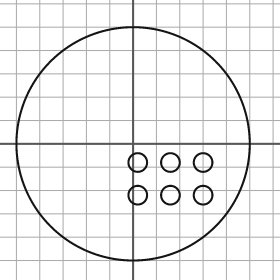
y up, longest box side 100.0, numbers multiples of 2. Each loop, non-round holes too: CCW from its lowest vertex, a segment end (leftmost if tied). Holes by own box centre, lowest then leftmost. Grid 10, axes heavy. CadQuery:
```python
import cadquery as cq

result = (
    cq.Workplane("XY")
    .moveTo(0.0, 0.0)
    .circle(50.0)
    .moveTo(2.0, -22.0)
    .circle(4.0)
    .moveTo(16.0, -22.0)
    .circle(4.0)
    .moveTo(30.0, -22.0)
    .circle(4.0)
    .moveTo(2.0, -8.0)
    .circle(4.0)
    .moveTo(16.0, -8.0)
    .circle(4.0)
    .moveTo(30.0, -8.0)
    .circle(4.0)
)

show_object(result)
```